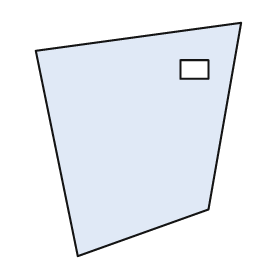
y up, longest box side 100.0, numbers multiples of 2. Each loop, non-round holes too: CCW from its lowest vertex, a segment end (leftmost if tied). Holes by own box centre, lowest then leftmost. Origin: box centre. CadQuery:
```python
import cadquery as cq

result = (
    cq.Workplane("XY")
    .moveTo(-26.0, -50.0)
    .lineTo(30.0, -30.0)
    .lineTo(44.0, 50.0)
    .lineTo(-44.0, 38.0)
    .close()
    .moveTo(18.0, 26.0)
    .lineTo(30.0, 26.0)
    .lineTo(30.0, 34.0)
    .lineTo(18.0, 34.0)
    .close()
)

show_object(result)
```